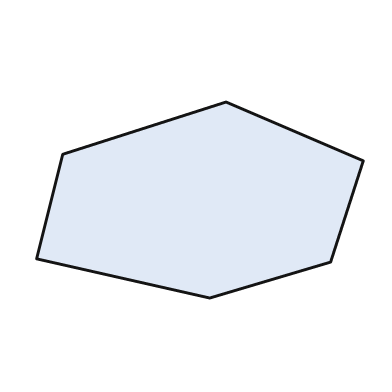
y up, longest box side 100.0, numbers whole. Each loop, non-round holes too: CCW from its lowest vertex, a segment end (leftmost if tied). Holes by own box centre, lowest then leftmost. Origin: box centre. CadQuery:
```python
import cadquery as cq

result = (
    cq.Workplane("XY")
    .moveTo(3.0, -30.0)
    .lineTo(40.0, -19.0)
    .lineTo(50.0, 12.0)
    .lineTo(8.0, 30.0)
    .lineTo(-42.0, 14.0)
    .lineTo(-50.0, -18.0)
    .close()
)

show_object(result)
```